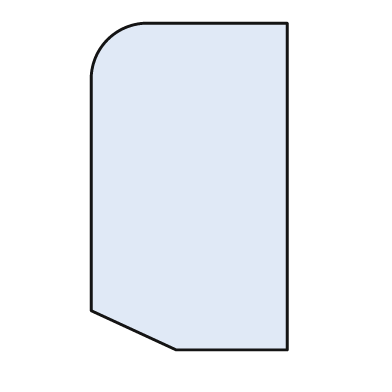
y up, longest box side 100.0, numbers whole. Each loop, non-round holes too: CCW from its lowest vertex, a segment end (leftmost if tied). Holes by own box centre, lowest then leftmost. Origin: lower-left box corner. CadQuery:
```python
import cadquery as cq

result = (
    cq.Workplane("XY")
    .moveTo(26.0, 0.0)
    .lineTo(60.0, 0.0)
    .lineTo(60.0, 100.0)
    .lineTo(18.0, 100.0)
    .threePointArc((5.0, 95.0), (0.0, 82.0))
    .lineTo(0.0, 12.0)
    .close()
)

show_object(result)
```